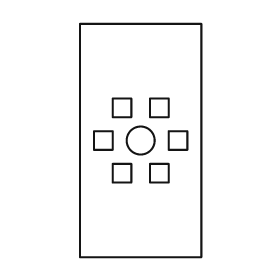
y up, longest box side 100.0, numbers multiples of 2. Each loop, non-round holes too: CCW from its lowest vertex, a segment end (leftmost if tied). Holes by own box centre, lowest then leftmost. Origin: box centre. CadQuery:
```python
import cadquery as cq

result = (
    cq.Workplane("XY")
    .moveTo(-26.0, -50.0)
    .lineTo(26.0, -50.0)
    .lineTo(26.0, 50.0)
    .lineTo(-26.0, 50.0)
    .close()
    .moveTo(-12.0, -18.0)
    .lineTo(-4.0, -18.0)
    .lineTo(-4.0, -10.0)
    .lineTo(-12.0, -10.0)
    .close()
    .moveTo(4.0, -18.0)
    .lineTo(12.0, -18.0)
    .lineTo(12.0, -10.0)
    .lineTo(4.0, -10.0)
    .close()
    .moveTo(-20.0, -4.0)
    .lineTo(-12.0, -4.0)
    .lineTo(-12.0, 4.0)
    .lineTo(-20.0, 4.0)
    .close()
    .moveTo(0.0, 0.0)
    .circle(6.0)
    .moveTo(12.0, -4.0)
    .lineTo(20.0, -4.0)
    .lineTo(20.0, 4.0)
    .lineTo(12.0, 4.0)
    .close()
    .moveTo(-12.0, 10.0)
    .lineTo(-4.0, 10.0)
    .lineTo(-4.0, 18.0)
    .lineTo(-12.0, 18.0)
    .close()
    .moveTo(4.0, 10.0)
    .lineTo(12.0, 10.0)
    .lineTo(12.0, 18.0)
    .lineTo(4.0, 18.0)
    .close()
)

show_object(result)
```